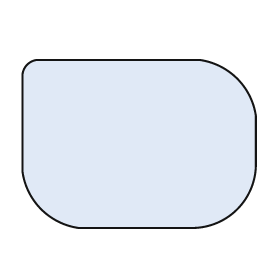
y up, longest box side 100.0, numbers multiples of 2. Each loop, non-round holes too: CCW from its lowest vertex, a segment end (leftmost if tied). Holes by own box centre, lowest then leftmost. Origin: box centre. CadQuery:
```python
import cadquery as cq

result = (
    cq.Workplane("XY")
    .moveTo(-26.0, -36.0)
    .lineTo(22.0, -36.0)
    .threePointArc((42.0, -28.0), (50.0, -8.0))
    .lineTo(50.0, 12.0)
    .threePointArc((42.0, 28.0), (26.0, 36.0))
    .lineTo(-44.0, 36.0)
    .threePointArc((-48.0, 34.0), (-50.0, 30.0))
    .lineTo(-50.0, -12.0)
    .threePointArc((-42.0, -28.0), (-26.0, -36.0))
    .close()
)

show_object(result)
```